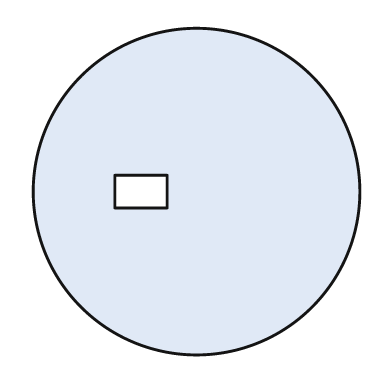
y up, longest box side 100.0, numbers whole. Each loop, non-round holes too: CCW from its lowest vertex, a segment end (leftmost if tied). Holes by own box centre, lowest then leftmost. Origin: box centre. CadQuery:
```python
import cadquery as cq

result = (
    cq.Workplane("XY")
    .moveTo(0.0, 0.0)
    .circle(50.0)
    .moveTo(-25.0, -5.0)
    .lineTo(-9.0, -5.0)
    .lineTo(-9.0, 5.0)
    .lineTo(-25.0, 5.0)
    .close()
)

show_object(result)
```